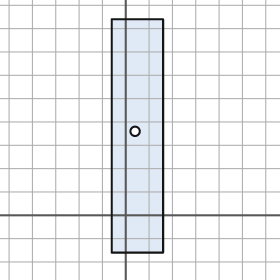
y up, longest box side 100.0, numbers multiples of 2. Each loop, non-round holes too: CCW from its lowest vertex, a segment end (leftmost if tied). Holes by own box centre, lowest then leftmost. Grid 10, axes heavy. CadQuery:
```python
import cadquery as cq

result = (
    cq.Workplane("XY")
    .moveTo(-6.0, -16.0)
    .lineTo(16.0, -16.0)
    .lineTo(16.0, 84.0)
    .lineTo(-6.0, 84.0)
    .close()
    .moveTo(4.0, 36.0)
    .circle(2.0)
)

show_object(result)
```